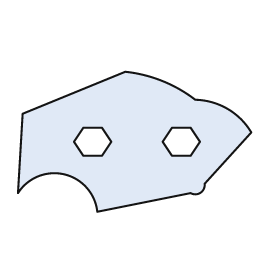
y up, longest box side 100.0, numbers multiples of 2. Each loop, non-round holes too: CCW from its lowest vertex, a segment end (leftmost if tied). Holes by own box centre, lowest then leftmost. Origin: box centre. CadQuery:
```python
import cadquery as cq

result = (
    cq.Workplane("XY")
    .moveTo(-16.0, -30.0)
    .lineTo(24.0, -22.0)
    .threePointArc((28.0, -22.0), (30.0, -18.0))
    .lineTo(50.0, 4.0)
    .threePointArc((40.0, 14.0), (26.0, 18.0))
    .threePointArc((12.0, 26.0), (-4.0, 30.0))
    .lineTo(-48.0, 12.0)
    .lineTo(-50.0, -22.0)
    .threePointArc((-30.0, -14.0), (-16.0, -30.0))
    .close()
    .moveTo(-22.0, -6.0)
    .lineTo(-14.0, -6.0)
    .lineTo(-10.0, 0.0)
    .lineTo(-14.0, 6.0)
    .lineTo(-22.0, 6.0)
    .lineTo(-26.0, 0.0)
    .close()
    .moveTo(16.0, -6.0)
    .lineTo(24.0, -6.0)
    .lineTo(28.0, 0.0)
    .lineTo(24.0, 6.0)
    .lineTo(16.0, 6.0)
    .lineTo(12.0, 0.0)
    .close()
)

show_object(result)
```